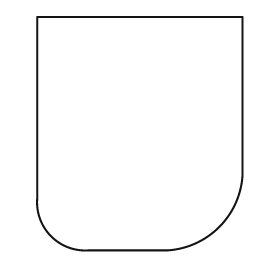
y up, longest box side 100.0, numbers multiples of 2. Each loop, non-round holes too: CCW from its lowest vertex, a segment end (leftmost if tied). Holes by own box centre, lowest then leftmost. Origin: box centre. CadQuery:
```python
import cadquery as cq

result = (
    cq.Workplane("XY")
    .moveTo(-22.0, -50.0)
    .lineTo(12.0, -50.0)
    .threePointArc((34.0, -40.0), (44.0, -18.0))
    .lineTo(44.0, 50.0)
    .lineTo(-44.0, 50.0)
    .lineTo(-44.0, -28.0)
    .threePointArc((-38.0, -44.0), (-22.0, -50.0))
    .close()
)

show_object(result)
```